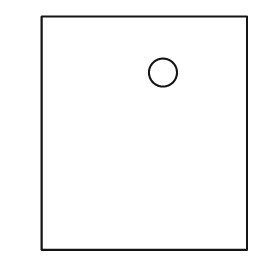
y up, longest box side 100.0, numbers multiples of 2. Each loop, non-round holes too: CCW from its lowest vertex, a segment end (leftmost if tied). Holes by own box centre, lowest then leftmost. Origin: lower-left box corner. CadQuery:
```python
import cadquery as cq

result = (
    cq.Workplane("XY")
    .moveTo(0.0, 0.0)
    .lineTo(88.0, 0.0)
    .lineTo(88.0, 100.0)
    .lineTo(0.0, 100.0)
    .close()
    .moveTo(52.0, 76.0)
    .circle(6.0)
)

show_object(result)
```